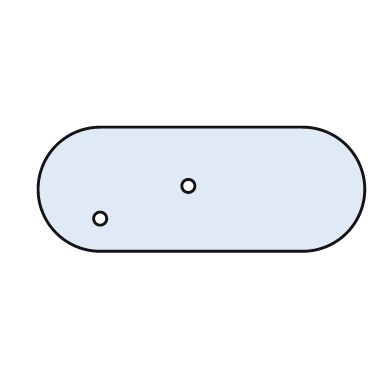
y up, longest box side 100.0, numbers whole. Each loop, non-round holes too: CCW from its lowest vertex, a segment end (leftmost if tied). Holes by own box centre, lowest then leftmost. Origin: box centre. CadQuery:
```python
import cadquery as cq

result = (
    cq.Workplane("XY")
    .moveTo(-31.0, -19.0)
    .lineTo(31.0, -19.0)
    .threePointArc((50.0, 0.0), (31.0, 19.0))
    .lineTo(-31.0, 19.0)
    .threePointArc((-50.0, 0.0), (-31.0, -19.0))
    .close()
    .moveTo(-31.0, -9.0)
    .circle(2.0)
    .moveTo(-4.0, 1.0)
    .circle(2.0)
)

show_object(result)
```